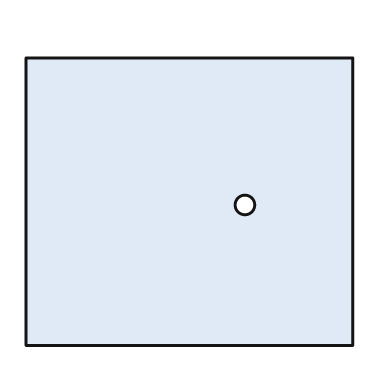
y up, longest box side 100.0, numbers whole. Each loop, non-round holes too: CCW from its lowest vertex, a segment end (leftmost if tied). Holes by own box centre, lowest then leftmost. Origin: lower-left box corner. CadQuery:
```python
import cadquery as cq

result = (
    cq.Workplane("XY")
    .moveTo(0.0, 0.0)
    .lineTo(100.0, 0.0)
    .lineTo(100.0, 88.0)
    .lineTo(0.0, 88.0)
    .close()
    .moveTo(67.0, 43.0)
    .circle(3.0)
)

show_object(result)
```